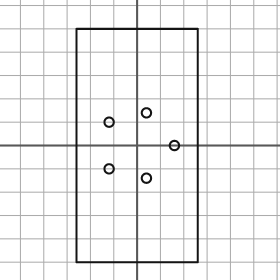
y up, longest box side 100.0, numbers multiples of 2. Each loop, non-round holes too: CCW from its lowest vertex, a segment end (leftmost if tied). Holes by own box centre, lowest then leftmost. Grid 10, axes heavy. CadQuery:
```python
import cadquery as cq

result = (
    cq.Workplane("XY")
    .moveTo(-26.0, -50.0)
    .lineTo(26.0, -50.0)
    .lineTo(26.0, 50.0)
    .lineTo(-26.0, 50.0)
    .close()
    .moveTo(4.0, -14.0)
    .circle(2.0)
    .moveTo(-12.0, -10.0)
    .circle(2.0)
    .moveTo(16.0, 0.0)
    .circle(2.0)
    .moveTo(-12.0, 10.0)
    .circle(2.0)
    .moveTo(4.0, 14.0)
    .circle(2.0)
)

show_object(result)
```